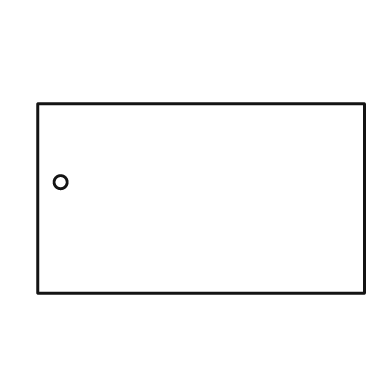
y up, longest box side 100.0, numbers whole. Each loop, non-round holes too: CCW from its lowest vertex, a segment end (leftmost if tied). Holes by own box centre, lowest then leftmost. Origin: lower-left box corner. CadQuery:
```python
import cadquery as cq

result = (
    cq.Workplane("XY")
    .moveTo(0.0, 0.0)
    .lineTo(100.0, 0.0)
    .lineTo(100.0, 58.0)
    .lineTo(0.0, 58.0)
    .close()
    .moveTo(7.0, 34.0)
    .circle(2.0)
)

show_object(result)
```